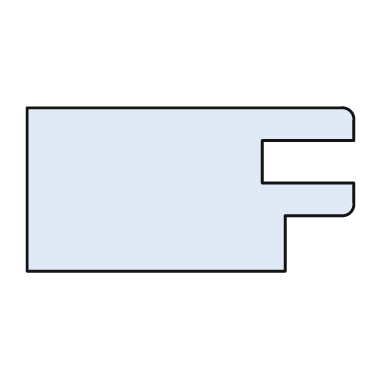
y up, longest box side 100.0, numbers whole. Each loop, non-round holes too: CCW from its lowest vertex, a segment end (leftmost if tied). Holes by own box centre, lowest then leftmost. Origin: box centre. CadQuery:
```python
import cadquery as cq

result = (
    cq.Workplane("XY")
    .moveTo(-50.0, -25.0)
    .lineTo(29.0, -25.0)
    .lineTo(29.0, -8.0)
    .lineTo(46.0, -8.0)
    .threePointArc((49.0, -7.0), (50.0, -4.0))
    .lineTo(50.0, 2.0)
    .lineTo(22.0, 2.0)
    .lineTo(22.0, 15.0)
    .lineTo(50.0, 15.0)
    .lineTo(50.0, 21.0)
    .threePointArc((49.0, 24.0), (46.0, 25.0))
    .lineTo(-50.0, 25.0)
    .close()
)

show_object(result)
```